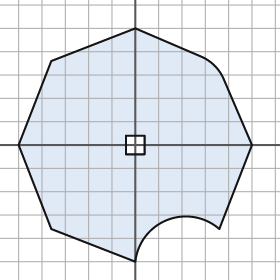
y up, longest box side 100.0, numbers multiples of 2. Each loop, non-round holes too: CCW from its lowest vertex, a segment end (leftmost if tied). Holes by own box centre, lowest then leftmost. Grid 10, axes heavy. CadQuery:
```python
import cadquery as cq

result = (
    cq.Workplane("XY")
    .moveTo(0.0, -50.0)
    .threePointArc((14.0, -32.0), (36.0, -36.0))
    .lineTo(50.0, 0.0)
    .lineTo(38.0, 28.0)
    .threePointArc((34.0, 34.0), (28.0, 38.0))
    .lineTo(0.0, 50.0)
    .lineTo(-36.0, 36.0)
    .lineTo(-50.0, 0.0)
    .lineTo(-36.0, -36.0)
    .close()
    .moveTo(-4.0, -4.0)
    .lineTo(4.0, -4.0)
    .lineTo(4.0, 4.0)
    .lineTo(-4.0, 4.0)
    .close()
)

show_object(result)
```